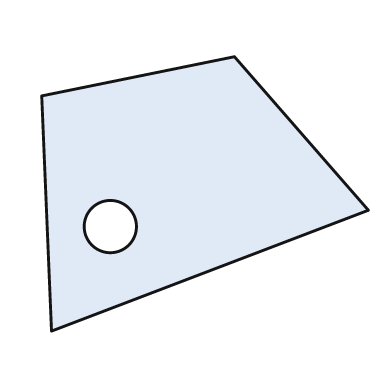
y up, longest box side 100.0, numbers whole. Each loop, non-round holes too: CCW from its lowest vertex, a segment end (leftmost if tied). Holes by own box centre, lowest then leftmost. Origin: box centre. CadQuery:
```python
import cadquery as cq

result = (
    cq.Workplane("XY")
    .moveTo(-47.0, -42.0)
    .lineTo(50.0, -5.0)
    .lineTo(9.0, 42.0)
    .lineTo(-50.0, 30.0)
    .close()
    .moveTo(-29.0, -10.0)
    .circle(8.0)
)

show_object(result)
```